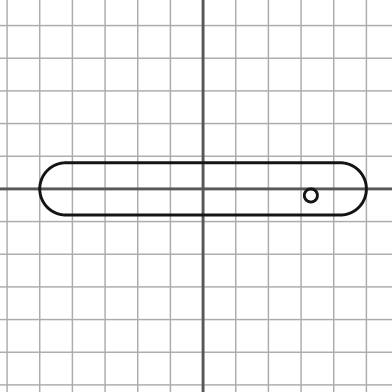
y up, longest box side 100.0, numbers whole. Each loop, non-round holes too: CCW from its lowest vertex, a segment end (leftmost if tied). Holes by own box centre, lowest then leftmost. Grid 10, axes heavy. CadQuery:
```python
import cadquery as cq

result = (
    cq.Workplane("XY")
    .moveTo(-42.0, -8.0)
    .lineTo(42.0, -8.0)
    .threePointArc((50.0, 0.0), (42.0, 8.0))
    .lineTo(-42.0, 8.0)
    .threePointArc((-50.0, 0.0), (-42.0, -8.0))
    .close()
    .moveTo(33.0, -2.0)
    .circle(2.0)
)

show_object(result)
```